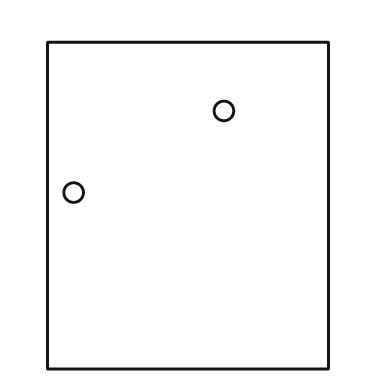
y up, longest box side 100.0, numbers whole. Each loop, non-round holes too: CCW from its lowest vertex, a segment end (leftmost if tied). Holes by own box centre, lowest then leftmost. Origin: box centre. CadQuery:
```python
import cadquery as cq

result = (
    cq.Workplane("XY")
    .moveTo(-43.0, -50.0)
    .lineTo(43.0, -50.0)
    .lineTo(43.0, 50.0)
    .lineTo(-43.0, 50.0)
    .close()
    .moveTo(-35.0, 4.0)
    .circle(3.0)
    .moveTo(11.0, 29.0)
    .circle(3.0)
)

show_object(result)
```